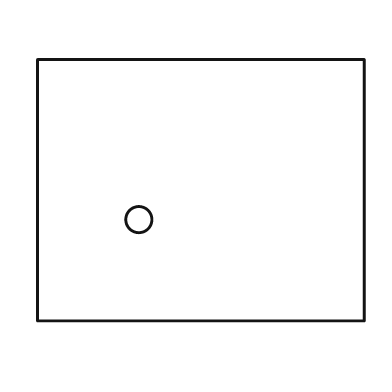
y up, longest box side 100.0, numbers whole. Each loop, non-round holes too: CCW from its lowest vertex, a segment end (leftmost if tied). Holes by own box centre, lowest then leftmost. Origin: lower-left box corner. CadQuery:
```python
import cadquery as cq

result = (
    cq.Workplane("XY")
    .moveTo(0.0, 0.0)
    .lineTo(100.0, 0.0)
    .lineTo(100.0, 80.0)
    .lineTo(0.0, 80.0)
    .close()
    .moveTo(31.0, 31.0)
    .circle(4.0)
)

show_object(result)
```